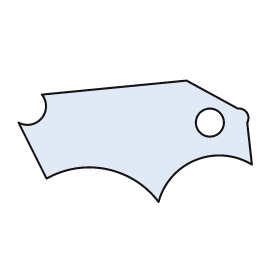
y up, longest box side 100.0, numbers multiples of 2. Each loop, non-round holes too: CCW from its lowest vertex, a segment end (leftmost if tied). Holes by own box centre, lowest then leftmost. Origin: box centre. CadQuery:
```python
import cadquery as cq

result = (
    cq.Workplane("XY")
    .moveTo(10.0, -26.0)
    .threePointArc((26.0, -8.0), (50.0, -10.0))
    .lineTo(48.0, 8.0)
    .threePointArc((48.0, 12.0), (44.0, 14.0))
    .lineTo(22.0, 26.0)
    .lineTo(-40.0, 20.0)
    .threePointArc((-40.0, 10.0), (-50.0, 8.0))
    .lineTo(-38.0, -16.0)
    .threePointArc((-12.0, -12.0), (10.0, -26.0))
    .close()
    .moveTo(32.0, 8.0)
    .circle(6.0)
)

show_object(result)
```